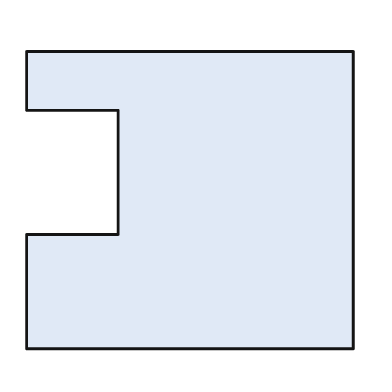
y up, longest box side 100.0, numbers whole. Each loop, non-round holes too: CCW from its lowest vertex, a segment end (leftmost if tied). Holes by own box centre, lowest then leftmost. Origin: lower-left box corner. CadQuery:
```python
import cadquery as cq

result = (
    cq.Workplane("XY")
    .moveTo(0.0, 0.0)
    .lineTo(100.0, 0.0)
    .lineTo(100.0, 91.0)
    .lineTo(0.0, 91.0)
    .lineTo(0.0, 73.0)
    .lineTo(28.0, 73.0)
    .lineTo(28.0, 35.0)
    .lineTo(0.0, 35.0)
    .close()
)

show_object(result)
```